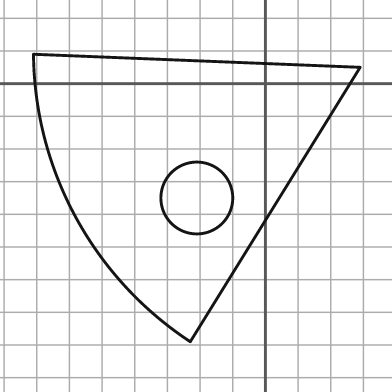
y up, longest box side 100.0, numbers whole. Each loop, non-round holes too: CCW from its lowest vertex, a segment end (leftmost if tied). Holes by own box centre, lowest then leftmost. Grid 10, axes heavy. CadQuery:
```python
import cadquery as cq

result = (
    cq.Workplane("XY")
    .moveTo(-23.0, -79.0)
    .lineTo(29.0, 5.0)
    .lineTo(-71.0, 9.0)
    .threePointArc((-58.0, -41.0), (-23.0, -79.0))
    .close()
    .moveTo(-21.0, -35.0)
    .circle(11.0)
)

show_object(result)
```